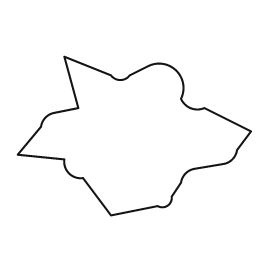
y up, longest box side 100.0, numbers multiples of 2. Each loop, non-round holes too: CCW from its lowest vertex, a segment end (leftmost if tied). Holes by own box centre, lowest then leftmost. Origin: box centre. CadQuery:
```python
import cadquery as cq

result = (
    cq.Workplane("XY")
    .moveTo(-10.0, -34.0)
    .lineTo(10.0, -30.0)
    .threePointArc((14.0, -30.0), (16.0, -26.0))
    .lineTo(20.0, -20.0)
    .threePointArc((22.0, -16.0), (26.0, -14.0))
    .lineTo(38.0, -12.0)
    .threePointArc((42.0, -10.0), (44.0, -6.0))
    .lineTo(50.0, 2.0)
    .lineTo(30.0, 12.0)
    .threePointArc((24.0, 12.0), (20.0, 16.0))
    .threePointArc((18.0, 28.0), (6.0, 30.0))
    .lineTo(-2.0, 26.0)
    .threePointArc((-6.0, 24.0), (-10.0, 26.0))
    .lineTo(-30.0, 34.0)
    .lineTo(-24.0, 12.0)
    .lineTo(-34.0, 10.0)
    .threePointArc((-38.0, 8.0), (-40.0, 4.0))
    .lineTo(-50.0, -8.0)
    .lineTo(-30.0, -10.0)
    .threePointArc((-28.0, -16.0), (-22.0, -18.0))
    .close()
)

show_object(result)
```